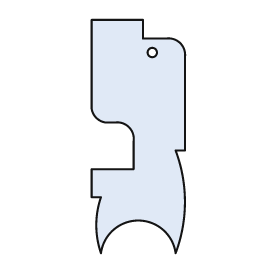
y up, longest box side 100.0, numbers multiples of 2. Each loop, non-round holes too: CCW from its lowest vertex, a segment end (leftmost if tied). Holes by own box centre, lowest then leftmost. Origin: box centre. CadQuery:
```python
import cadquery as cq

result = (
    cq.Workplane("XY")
    .moveTo(-16.0, -50.0)
    .threePointArc((0.0, -36.0), (16.0, -50.0))
    .threePointArc((20.0, -28.0), (16.0, -6.0))
    .lineTo(20.0, -6.0)
    .lineTo(20.0, 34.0)
    .threePointArc((18.0, 40.0), (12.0, 42.0))
    .lineTo(2.0, 42.0)
    .lineTo(2.0, 50.0)
    .lineTo(-20.0, 50.0)
    .lineTo(-20.0, 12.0)
    .threePointArc((-18.0, 8.0), (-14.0, 6.0))
    .lineTo(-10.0, 6.0)
    .threePointArc((-4.0, 4.0), (-2.0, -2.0))
    .lineTo(-2.0, -14.0)
    .lineTo(-20.0, -14.0)
    .lineTo(-20.0, -26.0)
    .lineTo(-16.0, -26.0)
    .threePointArc((-18.0, -38.0), (-16.0, -50.0))
    .close()
    .moveTo(6.0, 36.0)
    .circle(2.0)
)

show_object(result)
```